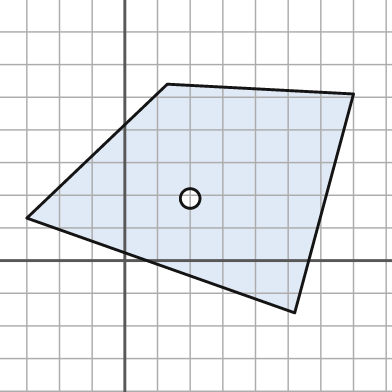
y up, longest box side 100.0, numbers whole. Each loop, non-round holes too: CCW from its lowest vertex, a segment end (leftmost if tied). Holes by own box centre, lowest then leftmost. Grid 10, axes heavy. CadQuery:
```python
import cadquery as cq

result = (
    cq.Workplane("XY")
    .moveTo(52.0, -16.0)
    .lineTo(70.0, 51.0)
    .lineTo(13.0, 54.0)
    .lineTo(-30.0, 13.0)
    .close()
    .moveTo(20.0, 19.0)
    .circle(3.0)
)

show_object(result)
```